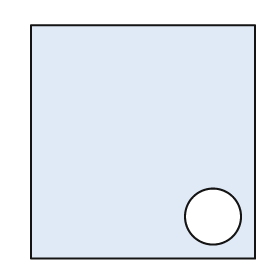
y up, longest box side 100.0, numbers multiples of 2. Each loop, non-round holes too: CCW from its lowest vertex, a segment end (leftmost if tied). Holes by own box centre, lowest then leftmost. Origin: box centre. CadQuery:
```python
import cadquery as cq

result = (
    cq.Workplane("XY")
    .moveTo(-48.0, -50.0)
    .lineTo(48.0, -50.0)
    .lineTo(48.0, 50.0)
    .lineTo(-48.0, 50.0)
    .close()
    .moveTo(30.0, -32.0)
    .circle(12.0)
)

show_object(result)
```